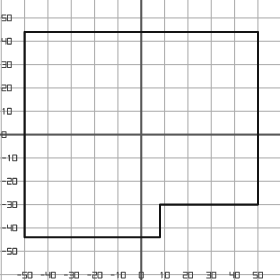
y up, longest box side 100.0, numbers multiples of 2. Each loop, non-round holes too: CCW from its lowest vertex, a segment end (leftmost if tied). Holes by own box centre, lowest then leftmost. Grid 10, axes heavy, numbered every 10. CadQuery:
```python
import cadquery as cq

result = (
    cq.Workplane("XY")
    .moveTo(-50.0, -44.0)
    .lineTo(8.0, -44.0)
    .lineTo(8.0, -30.0)
    .lineTo(50.0, -30.0)
    .lineTo(50.0, 44.0)
    .lineTo(-50.0, 44.0)
    .close()
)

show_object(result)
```